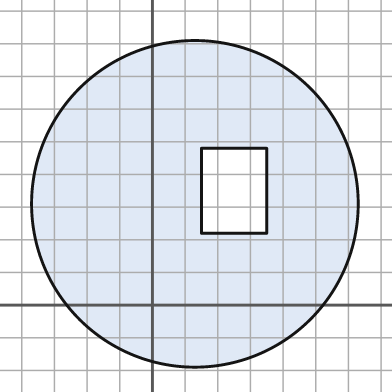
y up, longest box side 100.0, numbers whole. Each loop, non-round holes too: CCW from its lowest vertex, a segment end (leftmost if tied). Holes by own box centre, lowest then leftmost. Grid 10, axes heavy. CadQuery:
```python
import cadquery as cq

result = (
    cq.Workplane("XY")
    .moveTo(13.0, 31.0)
    .circle(50.0)
    .moveTo(15.0, 22.0)
    .lineTo(35.0, 22.0)
    .lineTo(35.0, 48.0)
    .lineTo(15.0, 48.0)
    .close()
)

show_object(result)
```